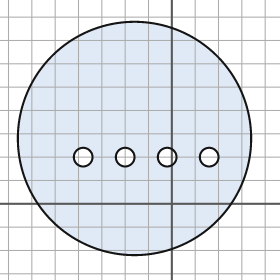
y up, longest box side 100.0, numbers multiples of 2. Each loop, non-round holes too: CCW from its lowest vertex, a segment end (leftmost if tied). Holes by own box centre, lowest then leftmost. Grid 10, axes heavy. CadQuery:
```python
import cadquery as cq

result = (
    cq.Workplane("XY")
    .moveTo(-16.0, 28.0)
    .circle(50.0)
    .moveTo(-38.0, 20.0)
    .circle(4.0)
    .moveTo(-20.0, 20.0)
    .circle(4.0)
    .moveTo(-2.0, 20.0)
    .circle(4.0)
    .moveTo(16.0, 20.0)
    .circle(4.0)
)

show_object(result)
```